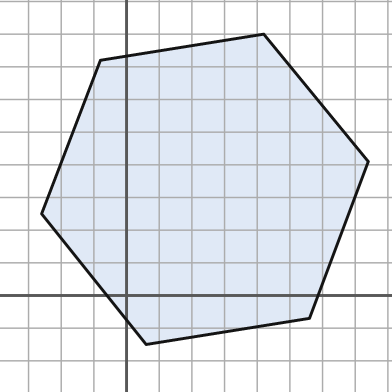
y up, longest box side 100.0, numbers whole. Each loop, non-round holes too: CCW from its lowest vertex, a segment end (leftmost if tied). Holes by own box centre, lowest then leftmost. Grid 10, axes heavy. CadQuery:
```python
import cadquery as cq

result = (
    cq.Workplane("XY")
    .moveTo(6.0, -15.0)
    .lineTo(56.0, -7.0)
    .lineTo(74.0, 41.0)
    .lineTo(42.0, 80.0)
    .lineTo(-8.0, 72.0)
    .lineTo(-26.0, 25.0)
    .close()
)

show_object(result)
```